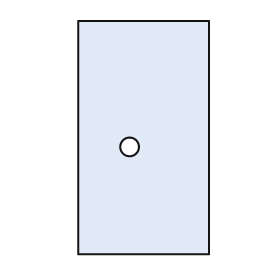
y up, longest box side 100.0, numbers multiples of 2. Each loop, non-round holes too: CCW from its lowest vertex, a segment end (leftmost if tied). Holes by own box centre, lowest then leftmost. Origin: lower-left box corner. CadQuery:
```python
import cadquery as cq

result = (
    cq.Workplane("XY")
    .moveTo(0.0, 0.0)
    .lineTo(56.0, 0.0)
    .lineTo(56.0, 100.0)
    .lineTo(0.0, 100.0)
    .close()
    .moveTo(22.0, 46.0)
    .circle(4.0)
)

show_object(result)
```